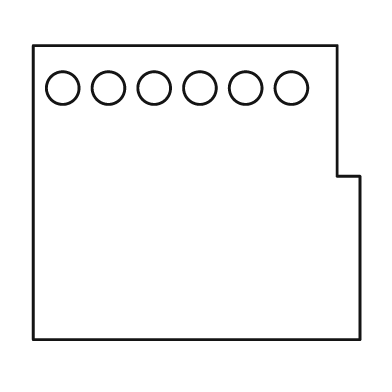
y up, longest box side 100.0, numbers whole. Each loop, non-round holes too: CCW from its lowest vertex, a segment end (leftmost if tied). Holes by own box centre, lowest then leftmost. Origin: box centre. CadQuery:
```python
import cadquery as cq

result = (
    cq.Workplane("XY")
    .moveTo(-50.0, -45.0)
    .lineTo(50.0, -45.0)
    .lineTo(50.0, 5.0)
    .lineTo(43.0, 5.0)
    .lineTo(43.0, 45.0)
    .lineTo(-50.0, 45.0)
    .close()
    .moveTo(-41.0, 32.0)
    .circle(5.0)
    .moveTo(-27.0, 32.0)
    .circle(5.0)
    .moveTo(-13.0, 32.0)
    .circle(5.0)
    .moveTo(1.0, 32.0)
    .circle(5.0)
    .moveTo(15.0, 32.0)
    .circle(5.0)
    .moveTo(29.0, 32.0)
    .circle(5.0)
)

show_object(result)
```